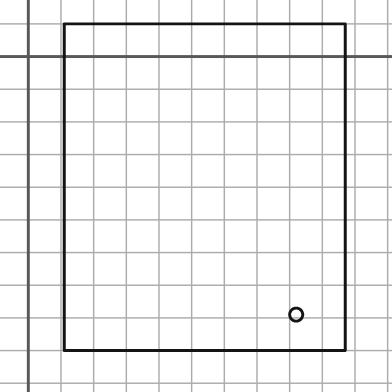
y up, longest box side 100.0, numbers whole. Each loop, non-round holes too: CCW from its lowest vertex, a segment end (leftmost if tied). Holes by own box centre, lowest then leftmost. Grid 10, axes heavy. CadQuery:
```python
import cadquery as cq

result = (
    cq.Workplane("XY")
    .moveTo(11.0, -90.0)
    .lineTo(97.0, -90.0)
    .lineTo(97.0, 10.0)
    .lineTo(11.0, 10.0)
    .close()
    .moveTo(82.0, -79.0)
    .circle(2.0)
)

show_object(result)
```